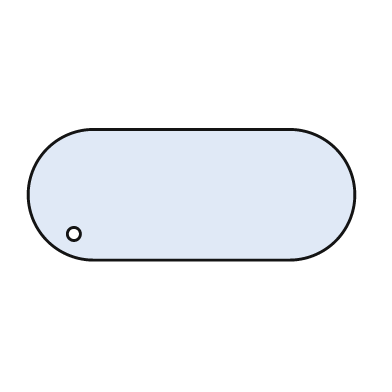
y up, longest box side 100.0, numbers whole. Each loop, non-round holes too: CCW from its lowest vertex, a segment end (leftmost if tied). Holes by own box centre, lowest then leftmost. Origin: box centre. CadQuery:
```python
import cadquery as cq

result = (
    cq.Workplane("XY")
    .moveTo(-30.0, -20.0)
    .lineTo(30.0, -20.0)
    .threePointArc((50.0, 0.0), (30.0, 20.0))
    .lineTo(-30.0, 20.0)
    .threePointArc((-50.0, 0.0), (-30.0, -20.0))
    .close()
    .moveTo(-36.0, -12.0)
    .circle(2.0)
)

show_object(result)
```